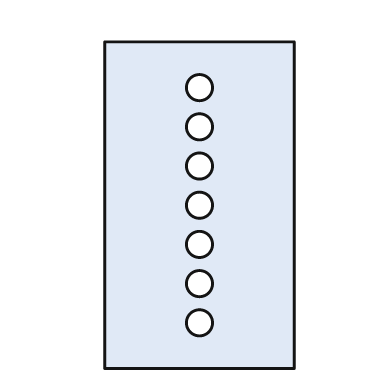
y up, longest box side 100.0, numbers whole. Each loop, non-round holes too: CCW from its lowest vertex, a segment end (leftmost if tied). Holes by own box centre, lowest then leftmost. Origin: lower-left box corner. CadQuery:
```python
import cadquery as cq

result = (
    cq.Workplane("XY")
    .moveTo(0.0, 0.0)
    .lineTo(58.0, 0.0)
    .lineTo(58.0, 100.0)
    .lineTo(0.0, 100.0)
    .close()
    .moveTo(29.0, 14.0)
    .circle(4.0)
    .moveTo(29.0, 26.0)
    .circle(4.0)
    .moveTo(29.0, 38.0)
    .circle(4.0)
    .moveTo(29.0, 50.0)
    .circle(4.0)
    .moveTo(29.0, 62.0)
    .circle(4.0)
    .moveTo(29.0, 74.0)
    .circle(4.0)
    .moveTo(29.0, 86.0)
    .circle(4.0)
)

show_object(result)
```